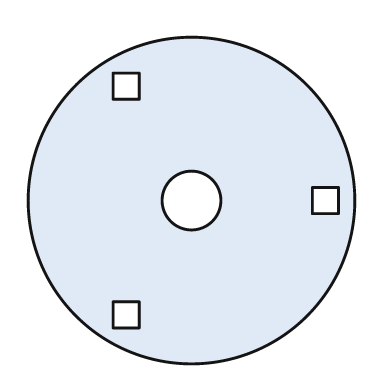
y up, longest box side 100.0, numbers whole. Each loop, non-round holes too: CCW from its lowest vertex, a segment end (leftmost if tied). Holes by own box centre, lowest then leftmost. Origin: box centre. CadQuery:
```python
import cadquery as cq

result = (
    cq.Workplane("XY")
    .moveTo(0.0, 0.0)
    .circle(50.0)
    .moveTo(-24.0, -39.0)
    .lineTo(-16.0, -39.0)
    .lineTo(-16.0, -31.0)
    .lineTo(-24.0, -31.0)
    .close()
    .moveTo(0.0, 0.0)
    .circle(9.0)
    .moveTo(37.0, -4.0)
    .lineTo(45.0, -4.0)
    .lineTo(45.0, 4.0)
    .lineTo(37.0, 4.0)
    .close()
    .moveTo(-24.0, 31.0)
    .lineTo(-16.0, 31.0)
    .lineTo(-16.0, 39.0)
    .lineTo(-24.0, 39.0)
    .close()
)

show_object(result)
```